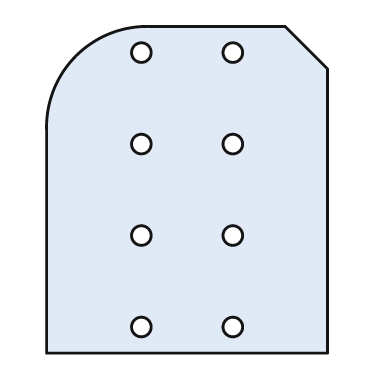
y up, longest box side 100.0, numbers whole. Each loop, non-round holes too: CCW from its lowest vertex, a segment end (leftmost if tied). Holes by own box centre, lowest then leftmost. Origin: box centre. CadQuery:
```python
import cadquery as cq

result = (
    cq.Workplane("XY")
    .moveTo(-43.0, -50.0)
    .lineTo(43.0, -50.0)
    .lineTo(43.0, 37.0)
    .lineTo(30.0, 50.0)
    .lineTo(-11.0, 50.0)
    .threePointArc((-34.0, 41.0), (-43.0, 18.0))
    .close()
    .moveTo(-14.0, -42.0)
    .circle(3.0)
    .moveTo(14.0, -42.0)
    .circle(3.0)
    .moveTo(-14.0, -14.0)
    .circle(3.0)
    .moveTo(14.0, -14.0)
    .circle(3.0)
    .moveTo(-14.0, 14.0)
    .circle(3.0)
    .moveTo(14.0, 14.0)
    .circle(3.0)
    .moveTo(-14.0, 42.0)
    .circle(3.0)
    .moveTo(14.0, 42.0)
    .circle(3.0)
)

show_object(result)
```